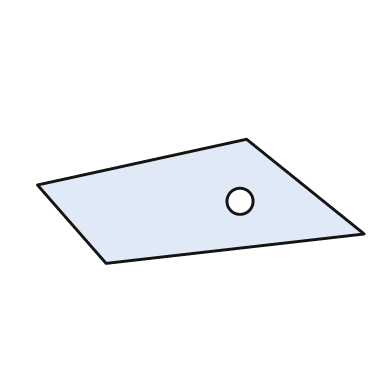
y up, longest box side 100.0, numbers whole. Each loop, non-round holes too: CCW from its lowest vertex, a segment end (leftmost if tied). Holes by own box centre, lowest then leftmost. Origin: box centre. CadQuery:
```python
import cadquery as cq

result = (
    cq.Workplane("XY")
    .moveTo(-29.0, -19.0)
    .lineTo(50.0, -10.0)
    .lineTo(14.0, 19.0)
    .lineTo(-50.0, 5.0)
    .close()
    .moveTo(12.0, 0.0)
    .circle(4.0)
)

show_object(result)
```